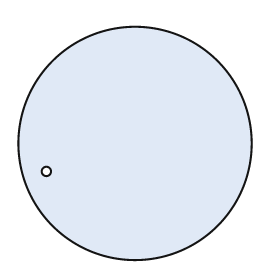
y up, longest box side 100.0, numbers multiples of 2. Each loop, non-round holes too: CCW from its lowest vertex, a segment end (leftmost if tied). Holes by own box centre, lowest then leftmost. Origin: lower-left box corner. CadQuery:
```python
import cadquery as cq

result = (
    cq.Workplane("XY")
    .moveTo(50.0, 50.0)
    .circle(50.0)
    .moveTo(12.0, 38.0)
    .circle(2.0)
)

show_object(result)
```